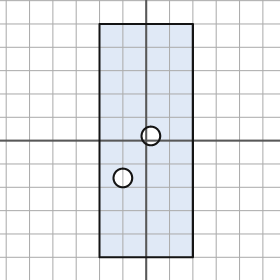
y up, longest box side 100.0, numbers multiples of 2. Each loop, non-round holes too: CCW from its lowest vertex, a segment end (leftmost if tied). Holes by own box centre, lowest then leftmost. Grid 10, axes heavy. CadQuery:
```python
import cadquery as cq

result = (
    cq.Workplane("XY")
    .moveTo(-20.0, -50.0)
    .lineTo(20.0, -50.0)
    .lineTo(20.0, 50.0)
    .lineTo(-20.0, 50.0)
    .close()
    .moveTo(-10.0, -16.0)
    .circle(4.0)
    .moveTo(2.0, 2.0)
    .circle(4.0)
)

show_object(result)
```